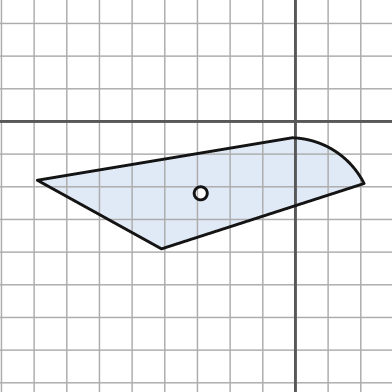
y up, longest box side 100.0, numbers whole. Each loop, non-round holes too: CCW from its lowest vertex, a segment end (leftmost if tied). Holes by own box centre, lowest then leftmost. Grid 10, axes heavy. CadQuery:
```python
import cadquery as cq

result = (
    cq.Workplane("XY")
    .moveTo(-41.0, -39.0)
    .lineTo(21.0, -19.0)
    .threePointArc((12.0, -9.0), (-1.0, -5.0))
    .lineTo(-79.0, -18.0)
    .close()
    .moveTo(-29.0, -22.0)
    .circle(2.0)
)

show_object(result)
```